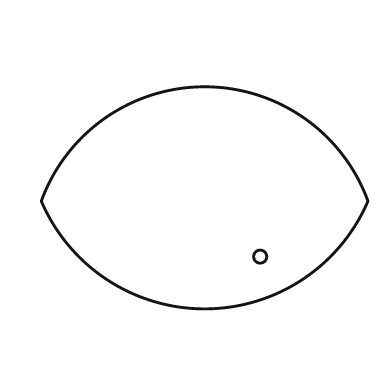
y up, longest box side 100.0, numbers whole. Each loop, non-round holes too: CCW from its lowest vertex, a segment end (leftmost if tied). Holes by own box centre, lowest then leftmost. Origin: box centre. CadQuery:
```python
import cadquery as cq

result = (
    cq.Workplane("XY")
    .moveTo(-50.0, -1.0)
    .threePointArc((0.0, -34.0), (50.0, -1.0))
    .threePointArc((0.0, 34.0), (-50.0, -1.0))
    .close()
    .moveTo(17.0, -18.0)
    .circle(2.0)
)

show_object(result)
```